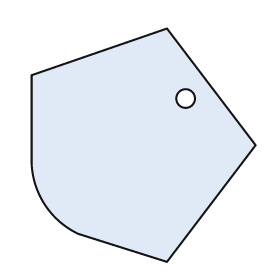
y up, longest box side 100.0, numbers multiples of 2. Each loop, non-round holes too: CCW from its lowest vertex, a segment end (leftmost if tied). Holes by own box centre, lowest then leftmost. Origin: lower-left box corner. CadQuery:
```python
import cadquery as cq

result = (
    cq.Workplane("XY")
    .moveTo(58.0, 0.0)
    .lineTo(96.0, 50.0)
    .lineTo(58.0, 100.0)
    .lineTo(0.0, 80.0)
    .lineTo(0.0, 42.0)
    .threePointArc((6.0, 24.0), (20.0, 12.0))
    .close()
    .moveTo(66.0, 70.0)
    .circle(4.0)
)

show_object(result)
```